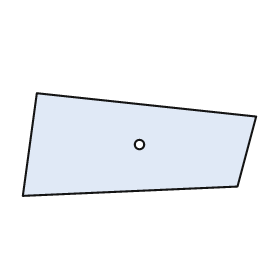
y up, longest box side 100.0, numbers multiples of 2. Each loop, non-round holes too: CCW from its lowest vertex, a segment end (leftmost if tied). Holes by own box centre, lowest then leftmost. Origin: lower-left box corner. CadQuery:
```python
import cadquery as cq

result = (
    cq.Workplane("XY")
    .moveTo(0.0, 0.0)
    .lineTo(92.0, 4.0)
    .lineTo(100.0, 34.0)
    .lineTo(6.0, 44.0)
    .close()
    .moveTo(50.0, 22.0)
    .circle(2.0)
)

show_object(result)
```